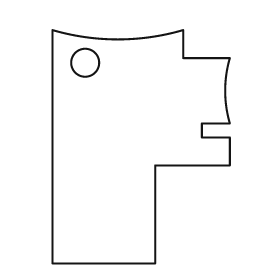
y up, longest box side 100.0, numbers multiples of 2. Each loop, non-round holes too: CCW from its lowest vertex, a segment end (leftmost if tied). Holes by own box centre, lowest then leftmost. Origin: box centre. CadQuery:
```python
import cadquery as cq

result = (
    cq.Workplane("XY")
    .moveTo(-38.0, -50.0)
    .lineTo(6.0, -50.0)
    .lineTo(6.0, -8.0)
    .lineTo(38.0, -8.0)
    .lineTo(38.0, 4.0)
    .lineTo(26.0, 4.0)
    .lineTo(26.0, 10.0)
    .lineTo(38.0, 10.0)
    .threePointArc((36.0, 24.0), (38.0, 38.0))
    .lineTo(18.0, 38.0)
    .lineTo(18.0, 50.0)
    .threePointArc((-10.0, 46.0), (-38.0, 50.0))
    .close()
    .moveTo(-24.0, 36.0)
    .circle(6.0)
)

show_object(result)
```